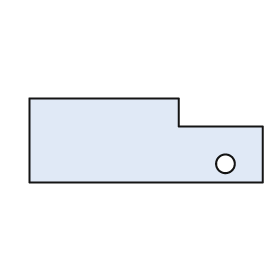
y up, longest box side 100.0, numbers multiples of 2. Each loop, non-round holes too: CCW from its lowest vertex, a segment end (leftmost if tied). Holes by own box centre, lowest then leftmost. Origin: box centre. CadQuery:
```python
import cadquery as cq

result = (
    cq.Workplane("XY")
    .moveTo(-50.0, -18.0)
    .lineTo(50.0, -18.0)
    .lineTo(50.0, 6.0)
    .lineTo(14.0, 6.0)
    .lineTo(14.0, 18.0)
    .lineTo(-50.0, 18.0)
    .close()
    .moveTo(34.0, -10.0)
    .circle(4.0)
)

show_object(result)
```